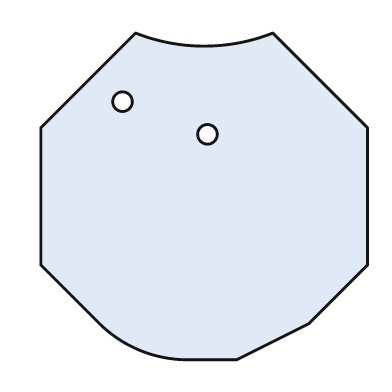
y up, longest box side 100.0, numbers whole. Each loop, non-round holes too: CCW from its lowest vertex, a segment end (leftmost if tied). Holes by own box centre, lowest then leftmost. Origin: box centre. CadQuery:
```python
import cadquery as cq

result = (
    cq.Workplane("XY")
    .moveTo(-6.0, -50.0)
    .lineTo(10.0, -50.0)
    .lineTo(32.0, -39.0)
    .lineTo(50.0, -21.0)
    .lineTo(50.0, 21.0)
    .lineTo(21.0, 50.0)
    .threePointArc((0.0, 46.0), (-21.0, 50.0))
    .lineTo(-50.0, 21.0)
    .lineTo(-50.0, -21.0)
    .lineTo(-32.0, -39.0)
    .threePointArc((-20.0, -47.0), (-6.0, -50.0))
    .close()
    .moveTo(1.0, 19.0)
    .circle(3.0)
    .moveTo(-25.0, 29.0)
    .circle(3.0)
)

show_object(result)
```